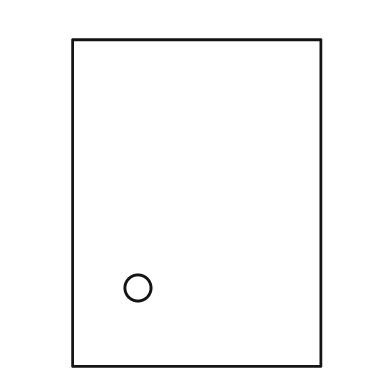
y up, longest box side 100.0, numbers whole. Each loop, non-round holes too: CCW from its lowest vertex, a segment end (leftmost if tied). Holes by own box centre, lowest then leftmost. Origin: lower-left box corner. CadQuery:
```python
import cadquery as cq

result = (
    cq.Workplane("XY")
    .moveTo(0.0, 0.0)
    .lineTo(76.0, 0.0)
    .lineTo(76.0, 100.0)
    .lineTo(0.0, 100.0)
    .close()
    .moveTo(20.0, 24.0)
    .circle(4.0)
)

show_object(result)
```